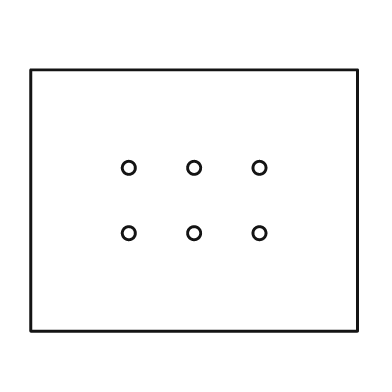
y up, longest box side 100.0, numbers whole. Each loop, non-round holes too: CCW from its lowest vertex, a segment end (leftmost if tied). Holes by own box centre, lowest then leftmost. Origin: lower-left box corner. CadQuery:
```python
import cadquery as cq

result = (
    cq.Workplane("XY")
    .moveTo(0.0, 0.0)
    .lineTo(100.0, 0.0)
    .lineTo(100.0, 80.0)
    .lineTo(0.0, 80.0)
    .close()
    .moveTo(30.0, 30.0)
    .circle(2.0)
    .moveTo(50.0, 30.0)
    .circle(2.0)
    .moveTo(70.0, 30.0)
    .circle(2.0)
    .moveTo(30.0, 50.0)
    .circle(2.0)
    .moveTo(50.0, 50.0)
    .circle(2.0)
    .moveTo(70.0, 50.0)
    .circle(2.0)
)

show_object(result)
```